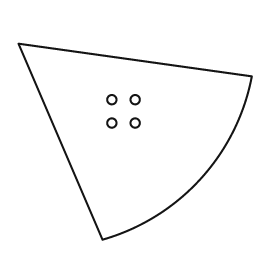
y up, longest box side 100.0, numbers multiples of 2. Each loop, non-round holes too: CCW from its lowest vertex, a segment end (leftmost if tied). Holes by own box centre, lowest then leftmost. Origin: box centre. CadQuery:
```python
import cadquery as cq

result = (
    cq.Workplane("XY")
    .moveTo(-14.0, -42.0)
    .threePointArc((28.0, -16.0), (50.0, 28.0))
    .lineTo(-50.0, 42.0)
    .close()
    .moveTo(-10.0, 8.0)
    .circle(2.0)
    .moveTo(0.0, 8.0)
    .circle(2.0)
    .moveTo(-10.0, 18.0)
    .circle(2.0)
    .moveTo(0.0, 18.0)
    .circle(2.0)
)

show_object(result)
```